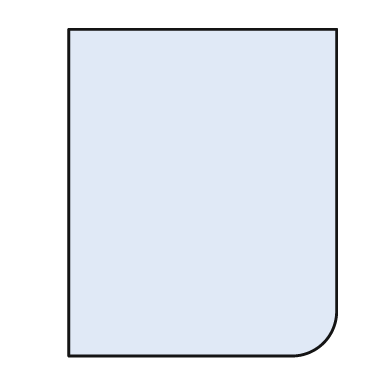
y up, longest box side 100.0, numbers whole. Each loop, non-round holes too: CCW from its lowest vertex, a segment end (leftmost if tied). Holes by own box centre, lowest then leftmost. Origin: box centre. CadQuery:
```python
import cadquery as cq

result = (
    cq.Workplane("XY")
    .moveTo(-41.0, -50.0)
    .lineTo(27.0, -50.0)
    .threePointArc((37.0, -46.0), (41.0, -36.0))
    .lineTo(41.0, 50.0)
    .lineTo(-41.0, 50.0)
    .close()
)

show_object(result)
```